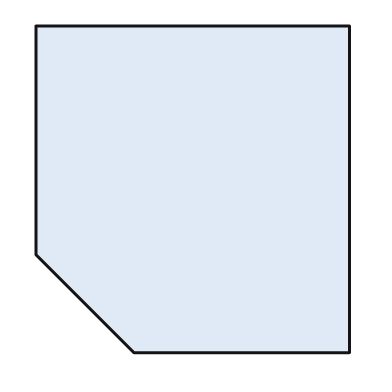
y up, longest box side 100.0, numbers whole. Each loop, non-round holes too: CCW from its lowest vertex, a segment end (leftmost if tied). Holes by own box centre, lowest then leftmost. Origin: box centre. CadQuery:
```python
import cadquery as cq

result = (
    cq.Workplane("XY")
    .moveTo(-18.0, -50.0)
    .lineTo(48.0, -50.0)
    .lineTo(48.0, 50.0)
    .lineTo(-48.0, 50.0)
    .lineTo(-48.0, -20.0)
    .close()
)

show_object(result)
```